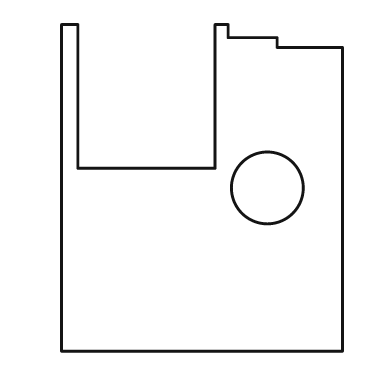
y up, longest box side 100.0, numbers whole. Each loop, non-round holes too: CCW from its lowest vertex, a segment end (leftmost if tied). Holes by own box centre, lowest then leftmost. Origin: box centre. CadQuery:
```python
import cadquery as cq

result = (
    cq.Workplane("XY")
    .moveTo(-43.0, -50.0)
    .lineTo(43.0, -50.0)
    .lineTo(43.0, 43.0)
    .lineTo(23.0, 43.0)
    .lineTo(23.0, 46.0)
    .lineTo(8.0, 46.0)
    .lineTo(8.0, 50.0)
    .lineTo(4.0, 50.0)
    .lineTo(4.0, 6.0)
    .lineTo(-38.0, 6.0)
    .lineTo(-38.0, 50.0)
    .lineTo(-43.0, 50.0)
    .close()
    .moveTo(20.0, 0.0)
    .circle(11.0)
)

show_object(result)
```